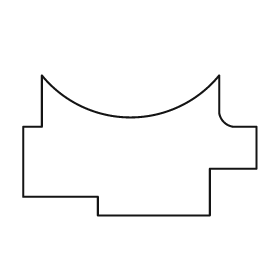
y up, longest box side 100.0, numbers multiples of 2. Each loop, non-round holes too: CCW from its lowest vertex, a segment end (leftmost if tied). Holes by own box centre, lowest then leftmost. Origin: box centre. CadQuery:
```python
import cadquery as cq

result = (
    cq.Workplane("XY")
    .moveTo(-18.0, -30.0)
    .lineTo(30.0, -30.0)
    .lineTo(30.0, -10.0)
    .lineTo(50.0, -10.0)
    .lineTo(50.0, 8.0)
    .lineTo(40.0, 8.0)
    .threePointArc((36.0, 10.0), (34.0, 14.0))
    .lineTo(34.0, 30.0)
    .threePointArc((-4.0, 12.0), (-42.0, 30.0))
    .lineTo(-42.0, 8.0)
    .lineTo(-50.0, 8.0)
    .lineTo(-50.0, -22.0)
    .lineTo(-18.0, -22.0)
    .close()
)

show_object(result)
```